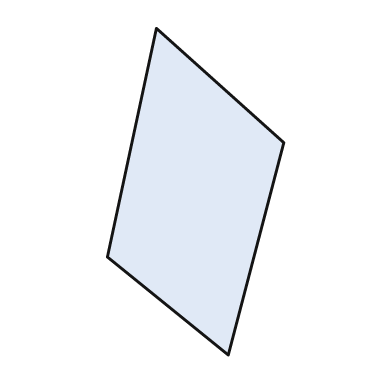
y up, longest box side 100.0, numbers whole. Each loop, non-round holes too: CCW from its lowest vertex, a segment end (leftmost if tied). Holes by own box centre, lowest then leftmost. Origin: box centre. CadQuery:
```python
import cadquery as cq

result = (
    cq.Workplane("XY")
    .moveTo(10.0, -50.0)
    .lineTo(27.0, 15.0)
    .lineTo(-12.0, 50.0)
    .lineTo(-27.0, -20.0)
    .close()
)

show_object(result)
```